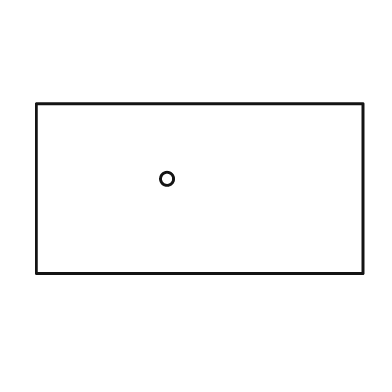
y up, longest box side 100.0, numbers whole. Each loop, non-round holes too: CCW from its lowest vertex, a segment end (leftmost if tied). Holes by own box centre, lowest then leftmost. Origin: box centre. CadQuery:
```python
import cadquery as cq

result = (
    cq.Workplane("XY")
    .moveTo(-50.0, -26.0)
    .lineTo(50.0, -26.0)
    .lineTo(50.0, 26.0)
    .lineTo(-50.0, 26.0)
    .close()
    .moveTo(-10.0, 3.0)
    .circle(2.0)
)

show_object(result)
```